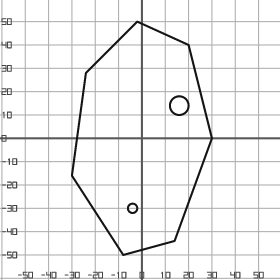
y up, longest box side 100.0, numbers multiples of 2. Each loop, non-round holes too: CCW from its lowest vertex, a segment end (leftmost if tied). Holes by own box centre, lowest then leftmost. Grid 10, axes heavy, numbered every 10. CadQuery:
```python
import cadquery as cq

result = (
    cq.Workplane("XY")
    .moveTo(-8.0, -50.0)
    .lineTo(14.0, -44.0)
    .lineTo(30.0, 0.0)
    .lineTo(20.0, 40.0)
    .lineTo(-2.0, 50.0)
    .lineTo(-24.0, 28.0)
    .lineTo(-30.0, -16.0)
    .close()
    .moveTo(-4.0, -30.0)
    .circle(2.0)
    .moveTo(16.0, 14.0)
    .circle(4.0)
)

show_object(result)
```